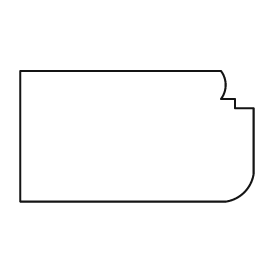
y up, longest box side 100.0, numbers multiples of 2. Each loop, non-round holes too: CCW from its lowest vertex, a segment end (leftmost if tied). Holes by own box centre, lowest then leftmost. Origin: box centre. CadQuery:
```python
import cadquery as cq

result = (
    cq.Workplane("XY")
    .moveTo(-50.0, -28.0)
    .lineTo(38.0, -28.0)
    .threePointArc((46.0, -24.0), (50.0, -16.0))
    .lineTo(50.0, 12.0)
    .lineTo(42.0, 12.0)
    .lineTo(42.0, 16.0)
    .lineTo(36.0, 16.0)
    .threePointArc((38.0, 22.0), (36.0, 28.0))
    .lineTo(-50.0, 28.0)
    .close()
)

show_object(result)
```